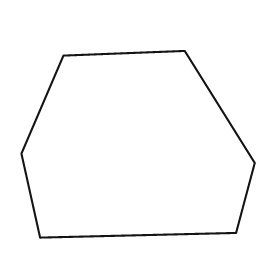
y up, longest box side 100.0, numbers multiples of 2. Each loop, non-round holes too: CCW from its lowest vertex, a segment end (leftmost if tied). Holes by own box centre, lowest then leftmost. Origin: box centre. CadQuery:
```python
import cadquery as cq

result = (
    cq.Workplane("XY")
    .moveTo(-42.0, -40.0)
    .lineTo(42.0, -38.0)
    .lineTo(50.0, -8.0)
    .lineTo(20.0, 40.0)
    .lineTo(-32.0, 38.0)
    .lineTo(-50.0, -4.0)
    .close()
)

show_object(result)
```